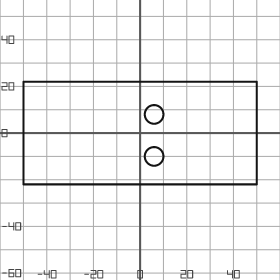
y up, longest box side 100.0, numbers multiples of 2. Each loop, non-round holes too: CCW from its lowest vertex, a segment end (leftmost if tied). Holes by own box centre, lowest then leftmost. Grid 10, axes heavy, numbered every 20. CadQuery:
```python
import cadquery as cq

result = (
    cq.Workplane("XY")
    .moveTo(-50.0, -22.0)
    .lineTo(50.0, -22.0)
    .lineTo(50.0, 22.0)
    .lineTo(-50.0, 22.0)
    .close()
    .moveTo(6.0, -10.0)
    .circle(4.0)
    .moveTo(6.0, 8.0)
    .circle(4.0)
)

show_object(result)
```